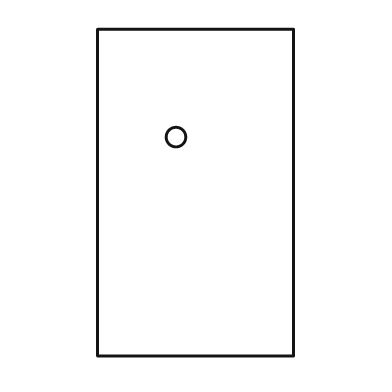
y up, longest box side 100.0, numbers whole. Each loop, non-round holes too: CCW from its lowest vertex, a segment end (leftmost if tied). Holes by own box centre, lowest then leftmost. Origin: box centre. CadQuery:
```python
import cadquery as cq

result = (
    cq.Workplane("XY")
    .moveTo(-30.0, -50.0)
    .lineTo(30.0, -50.0)
    .lineTo(30.0, 50.0)
    .lineTo(-30.0, 50.0)
    .close()
    .moveTo(-6.0, 17.0)
    .circle(3.0)
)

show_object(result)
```